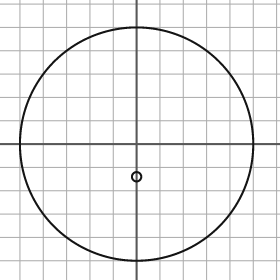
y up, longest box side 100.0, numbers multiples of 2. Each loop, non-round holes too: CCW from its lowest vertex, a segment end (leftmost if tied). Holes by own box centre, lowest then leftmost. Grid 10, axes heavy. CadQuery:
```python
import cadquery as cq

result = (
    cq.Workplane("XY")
    .moveTo(0.0, 0.0)
    .circle(50.0)
    .moveTo(0.0, -14.0)
    .circle(2.0)
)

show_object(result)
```